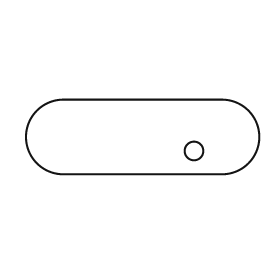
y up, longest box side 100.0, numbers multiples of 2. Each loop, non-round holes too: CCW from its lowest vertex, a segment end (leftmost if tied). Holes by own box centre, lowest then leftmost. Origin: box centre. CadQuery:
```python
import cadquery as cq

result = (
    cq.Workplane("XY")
    .moveTo(-34.0, -16.0)
    .lineTo(34.0, -16.0)
    .threePointArc((50.0, 0.0), (34.0, 16.0))
    .lineTo(-34.0, 16.0)
    .threePointArc((-50.0, 0.0), (-34.0, -16.0))
    .close()
    .moveTo(22.0, -6.0)
    .circle(4.0)
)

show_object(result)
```